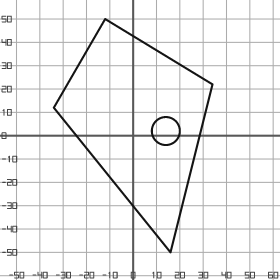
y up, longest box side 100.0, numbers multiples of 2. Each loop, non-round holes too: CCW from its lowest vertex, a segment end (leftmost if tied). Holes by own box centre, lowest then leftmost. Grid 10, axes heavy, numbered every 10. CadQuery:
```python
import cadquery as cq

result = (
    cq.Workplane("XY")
    .moveTo(16.0, -50.0)
    .lineTo(34.0, 22.0)
    .lineTo(-12.0, 50.0)
    .lineTo(-34.0, 12.0)
    .close()
    .moveTo(14.0, 2.0)
    .circle(6.0)
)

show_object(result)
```